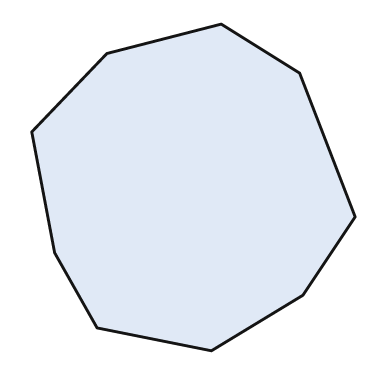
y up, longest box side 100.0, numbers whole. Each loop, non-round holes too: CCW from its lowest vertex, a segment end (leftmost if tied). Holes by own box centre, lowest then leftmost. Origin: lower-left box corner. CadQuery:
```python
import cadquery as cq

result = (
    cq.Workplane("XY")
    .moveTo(55.0, 0.0)
    .lineTo(83.0, 17.0)
    .lineTo(99.0, 41.0)
    .lineTo(82.0, 85.0)
    .lineTo(58.0, 100.0)
    .lineTo(23.0, 91.0)
    .lineTo(0.0, 67.0)
    .lineTo(7.0, 30.0)
    .lineTo(20.0, 7.0)
    .close()
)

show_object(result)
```